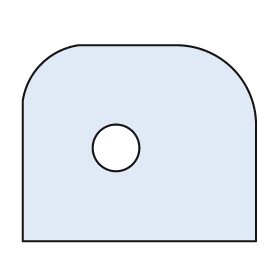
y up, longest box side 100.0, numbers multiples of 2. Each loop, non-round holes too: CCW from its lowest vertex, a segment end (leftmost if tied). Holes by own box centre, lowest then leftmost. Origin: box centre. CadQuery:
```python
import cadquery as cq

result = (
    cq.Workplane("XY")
    .moveTo(-50.0, -42.0)
    .lineTo(50.0, -42.0)
    .lineTo(50.0, 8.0)
    .threePointArc((40.0, 32.0), (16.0, 42.0))
    .lineTo(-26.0, 42.0)
    .threePointArc((-42.0, 34.0), (-50.0, 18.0))
    .close()
    .moveTo(-10.0, -2.0)
    .circle(10.0)
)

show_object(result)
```